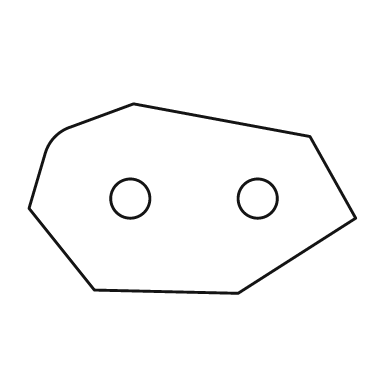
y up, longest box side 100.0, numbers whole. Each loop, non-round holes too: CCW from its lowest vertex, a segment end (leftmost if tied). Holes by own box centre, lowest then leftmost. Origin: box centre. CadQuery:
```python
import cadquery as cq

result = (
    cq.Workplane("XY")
    .moveTo(14.0, -29.0)
    .lineTo(50.0, -6.0)
    .lineTo(36.0, 19.0)
    .lineTo(-18.0, 29.0)
    .lineTo(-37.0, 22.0)
    .threePointArc((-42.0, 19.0), (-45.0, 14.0))
    .lineTo(-50.0, -3.0)
    .lineTo(-30.0, -28.0)
    .close()
    .moveTo(-19.0, 0.0)
    .circle(6.0)
    .moveTo(20.0, 0.0)
    .circle(6.0)
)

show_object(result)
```